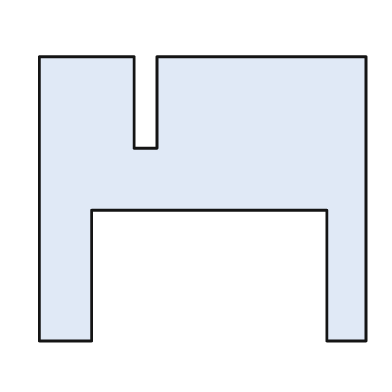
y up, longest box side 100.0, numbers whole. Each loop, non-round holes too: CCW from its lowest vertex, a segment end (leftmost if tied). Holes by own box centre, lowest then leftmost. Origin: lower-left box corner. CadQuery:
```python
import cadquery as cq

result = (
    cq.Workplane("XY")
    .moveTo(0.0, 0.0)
    .lineTo(16.0, 0.0)
    .lineTo(16.0, 40.0)
    .lineTo(88.0, 40.0)
    .lineTo(88.0, 0.0)
    .lineTo(100.0, 0.0)
    .lineTo(100.0, 87.0)
    .lineTo(36.0, 87.0)
    .lineTo(36.0, 59.0)
    .lineTo(29.0, 59.0)
    .lineTo(29.0, 87.0)
    .lineTo(0.0, 87.0)
    .close()
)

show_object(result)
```